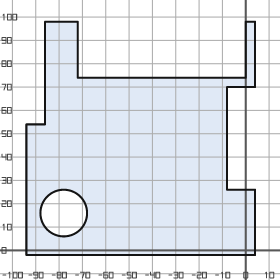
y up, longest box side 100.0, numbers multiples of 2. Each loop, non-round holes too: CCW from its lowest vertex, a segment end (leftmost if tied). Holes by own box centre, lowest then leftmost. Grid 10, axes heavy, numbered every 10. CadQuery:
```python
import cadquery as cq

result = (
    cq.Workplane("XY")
    .moveTo(-94.0, -2.0)
    .lineTo(4.0, -2.0)
    .lineTo(4.0, 26.0)
    .lineTo(-8.0, 26.0)
    .lineTo(-8.0, 70.0)
    .lineTo(4.0, 70.0)
    .lineTo(4.0, 98.0)
    .lineTo(0.0, 98.0)
    .lineTo(0.0, 74.0)
    .lineTo(-72.0, 74.0)
    .lineTo(-72.0, 98.0)
    .lineTo(-86.0, 98.0)
    .lineTo(-86.0, 54.0)
    .lineTo(-94.0, 54.0)
    .close()
    .moveTo(-78.0, 16.0)
    .circle(10.0)
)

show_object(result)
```